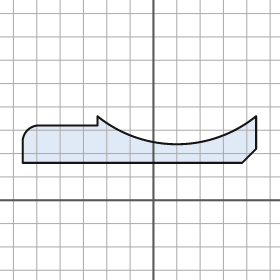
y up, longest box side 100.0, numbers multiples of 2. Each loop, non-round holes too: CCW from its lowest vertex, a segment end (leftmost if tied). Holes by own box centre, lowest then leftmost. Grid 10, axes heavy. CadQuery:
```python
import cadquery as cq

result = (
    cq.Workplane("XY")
    .moveTo(-56.0, 16.0)
    .lineTo(38.0, 16.0)
    .lineTo(44.0, 22.0)
    .lineTo(44.0, 36.0)
    .threePointArc((10.0, 24.0), (-24.0, 36.0))
    .lineTo(-24.0, 32.0)
    .lineTo(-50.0, 32.0)
    .threePointArc((-54.0, 30.0), (-56.0, 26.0))
    .close()
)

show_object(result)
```